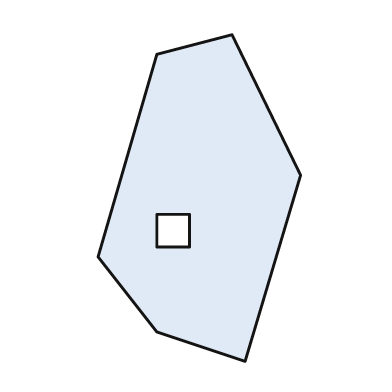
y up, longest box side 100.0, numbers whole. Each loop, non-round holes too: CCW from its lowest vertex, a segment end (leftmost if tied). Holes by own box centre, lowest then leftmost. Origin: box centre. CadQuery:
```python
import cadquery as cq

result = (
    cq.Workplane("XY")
    .moveTo(14.0, -50.0)
    .lineTo(31.0, 7.0)
    .lineTo(10.0, 50.0)
    .lineTo(-13.0, 44.0)
    .lineTo(-31.0, -18.0)
    .lineTo(-13.0, -41.0)
    .close()
    .moveTo(-13.0, -15.0)
    .lineTo(-3.0, -15.0)
    .lineTo(-3.0, -5.0)
    .lineTo(-13.0, -5.0)
    .close()
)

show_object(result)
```